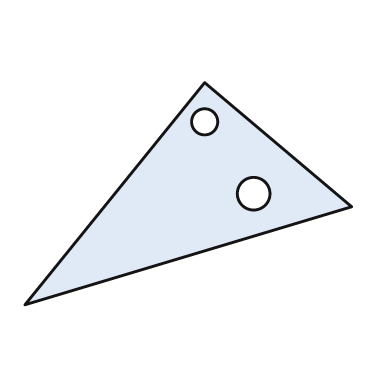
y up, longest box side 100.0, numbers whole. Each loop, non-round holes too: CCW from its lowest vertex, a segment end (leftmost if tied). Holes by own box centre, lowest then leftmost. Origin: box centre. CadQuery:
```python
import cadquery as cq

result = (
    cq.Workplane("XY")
    .moveTo(-50.0, -34.0)
    .lineTo(50.0, -4.0)
    .lineTo(5.0, 34.0)
    .close()
    .moveTo(20.0, 0.0)
    .circle(5.0)
    .moveTo(5.0, 22.0)
    .circle(4.0)
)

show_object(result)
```